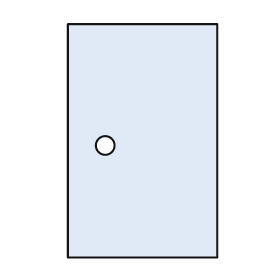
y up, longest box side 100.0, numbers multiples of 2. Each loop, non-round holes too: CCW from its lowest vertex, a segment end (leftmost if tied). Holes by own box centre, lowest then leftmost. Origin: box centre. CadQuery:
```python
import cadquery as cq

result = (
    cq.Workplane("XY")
    .moveTo(-32.0, -50.0)
    .lineTo(32.0, -50.0)
    .lineTo(32.0, 50.0)
    .lineTo(-32.0, 50.0)
    .close()
    .moveTo(-16.0, -2.0)
    .circle(4.0)
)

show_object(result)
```